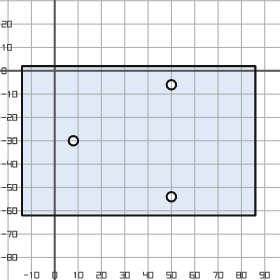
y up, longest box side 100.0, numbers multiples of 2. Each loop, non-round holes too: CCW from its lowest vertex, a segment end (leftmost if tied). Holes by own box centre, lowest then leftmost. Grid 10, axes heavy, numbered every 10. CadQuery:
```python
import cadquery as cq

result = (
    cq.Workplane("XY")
    .moveTo(-14.0, -62.0)
    .lineTo(86.0, -62.0)
    .lineTo(86.0, 2.0)
    .lineTo(-14.0, 2.0)
    .close()
    .moveTo(50.0, -54.0)
    .circle(2.0)
    .moveTo(8.0, -30.0)
    .circle(2.0)
    .moveTo(50.0, -6.0)
    .circle(2.0)
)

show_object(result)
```